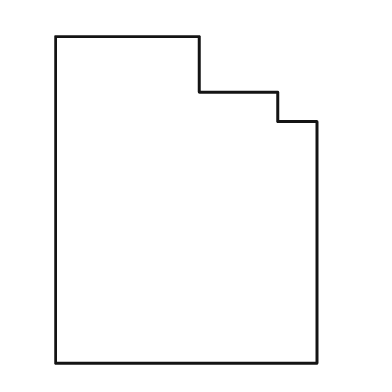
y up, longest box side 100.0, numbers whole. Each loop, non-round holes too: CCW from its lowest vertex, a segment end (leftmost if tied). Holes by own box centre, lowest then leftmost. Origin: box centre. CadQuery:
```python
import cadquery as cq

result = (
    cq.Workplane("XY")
    .moveTo(-40.0, -50.0)
    .lineTo(40.0, -50.0)
    .lineTo(40.0, 24.0)
    .lineTo(28.0, 24.0)
    .lineTo(28.0, 33.0)
    .lineTo(4.0, 33.0)
    .lineTo(4.0, 50.0)
    .lineTo(-40.0, 50.0)
    .close()
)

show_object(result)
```